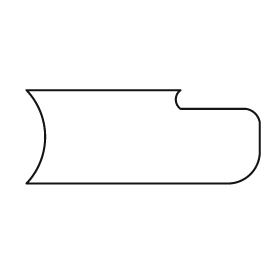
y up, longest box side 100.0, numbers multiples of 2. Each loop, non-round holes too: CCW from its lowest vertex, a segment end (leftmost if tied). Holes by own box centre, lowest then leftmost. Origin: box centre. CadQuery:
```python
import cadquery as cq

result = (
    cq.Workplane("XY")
    .moveTo(-50.0, -20.0)
    .lineTo(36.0, -20.0)
    .threePointArc((46.0, -16.0), (50.0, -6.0))
    .lineTo(50.0, 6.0)
    .threePointArc((48.0, 10.0), (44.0, 12.0))
    .lineTo(16.0, 12.0)
    .threePointArc((14.0, 16.0), (16.0, 20.0))
    .lineTo(-50.0, 20.0)
    .threePointArc((-42.0, 0.0), (-50.0, -20.0))
    .close()
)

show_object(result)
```